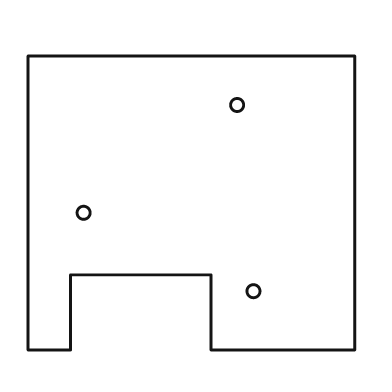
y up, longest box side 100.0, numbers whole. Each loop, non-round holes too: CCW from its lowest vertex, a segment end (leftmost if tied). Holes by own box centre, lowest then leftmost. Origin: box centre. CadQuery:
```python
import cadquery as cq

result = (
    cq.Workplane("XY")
    .moveTo(-50.0, -45.0)
    .lineTo(-37.0, -45.0)
    .lineTo(-37.0, -22.0)
    .lineTo(6.0, -22.0)
    .lineTo(6.0, -45.0)
    .lineTo(50.0, -45.0)
    .lineTo(50.0, 45.0)
    .lineTo(-50.0, 45.0)
    .close()
    .moveTo(19.0, -27.0)
    .circle(2.0)
    .moveTo(-33.0, -3.0)
    .circle(2.0)
    .moveTo(14.0, 30.0)
    .circle(2.0)
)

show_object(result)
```